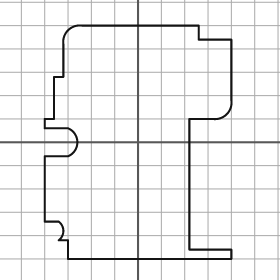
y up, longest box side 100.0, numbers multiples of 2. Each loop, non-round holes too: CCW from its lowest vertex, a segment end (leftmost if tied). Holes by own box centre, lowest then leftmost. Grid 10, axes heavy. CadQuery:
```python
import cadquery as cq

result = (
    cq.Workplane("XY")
    .moveTo(-30.0, -50.0)
    .lineTo(40.0, -50.0)
    .lineTo(40.0, -46.0)
    .lineTo(22.0, -46.0)
    .lineTo(22.0, 10.0)
    .lineTo(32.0, 10.0)
    .threePointArc((38.0, 12.0), (40.0, 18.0))
    .lineTo(40.0, 44.0)
    .lineTo(26.0, 44.0)
    .lineTo(26.0, 50.0)
    .lineTo(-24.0, 50.0)
    .threePointArc((-30.0, 48.0), (-32.0, 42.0))
    .lineTo(-32.0, 28.0)
    .lineTo(-36.0, 28.0)
    .lineTo(-36.0, 10.0)
    .lineTo(-40.0, 10.0)
    .lineTo(-40.0, 6.0)
    .lineTo(-30.0, 6.0)
    .threePointArc((-26.0, 0.0), (-30.0, -6.0))
    .lineTo(-40.0, -6.0)
    .lineTo(-40.0, -34.0)
    .lineTo(-34.0, -34.0)
    .threePointArc((-32.0, -38.0), (-34.0, -42.0))
    .lineTo(-30.0, -42.0)
    .close()
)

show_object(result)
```